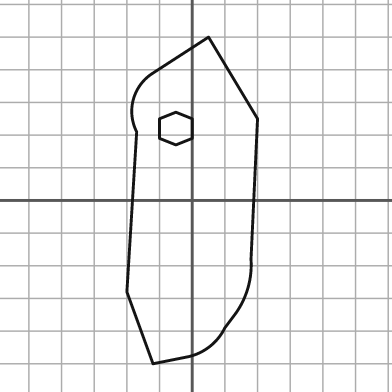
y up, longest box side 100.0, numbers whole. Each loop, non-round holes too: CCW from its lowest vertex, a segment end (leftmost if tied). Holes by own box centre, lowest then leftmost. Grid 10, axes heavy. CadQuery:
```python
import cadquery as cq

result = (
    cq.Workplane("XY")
    .moveTo(-12.0, -50.0)
    .lineTo(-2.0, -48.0)
    .threePointArc((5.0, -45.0), (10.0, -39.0))
    .lineTo(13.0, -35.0)
    .threePointArc((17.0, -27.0), (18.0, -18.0))
    .lineTo(20.0, 25.0)
    .lineTo(5.0, 50.0)
    .lineTo(-12.0, 39.0)
    .threePointArc((-18.0, 31.0), (-17.0, 21.0))
    .lineTo(-20.0, -28.0)
    .close()
    .moveTo(-5.0, 17.0)
    .lineTo(0.0, 19.0)
    .lineTo(0.0, 25.0)
    .lineTo(-5.0, 27.0)
    .lineTo(-10.0, 25.0)
    .lineTo(-10.0, 19.0)
    .close()
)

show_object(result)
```